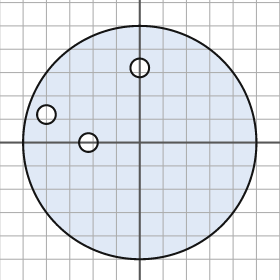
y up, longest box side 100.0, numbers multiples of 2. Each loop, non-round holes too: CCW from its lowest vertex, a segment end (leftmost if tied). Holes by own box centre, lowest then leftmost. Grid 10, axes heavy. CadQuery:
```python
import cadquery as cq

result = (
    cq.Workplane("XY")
    .moveTo(0.0, 0.0)
    .circle(50.0)
    .moveTo(-22.0, 0.0)
    .circle(4.0)
    .moveTo(-40.0, 12.0)
    .circle(4.0)
    .moveTo(0.0, 32.0)
    .circle(4.0)
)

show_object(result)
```